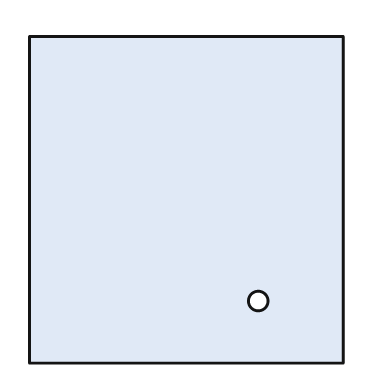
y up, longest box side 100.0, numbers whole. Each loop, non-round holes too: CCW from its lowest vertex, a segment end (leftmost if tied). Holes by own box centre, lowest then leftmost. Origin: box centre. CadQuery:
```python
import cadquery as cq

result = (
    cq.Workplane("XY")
    .moveTo(-48.0, -50.0)
    .lineTo(48.0, -50.0)
    .lineTo(48.0, 50.0)
    .lineTo(-48.0, 50.0)
    .close()
    .moveTo(22.0, -31.0)
    .circle(3.0)
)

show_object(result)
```